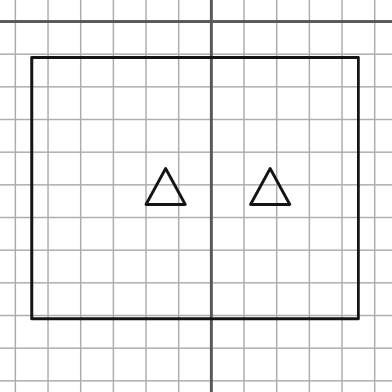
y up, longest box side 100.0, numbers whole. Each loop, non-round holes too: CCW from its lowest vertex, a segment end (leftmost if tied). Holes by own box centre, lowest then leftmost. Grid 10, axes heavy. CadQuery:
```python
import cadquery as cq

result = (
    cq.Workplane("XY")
    .moveTo(-55.0, -91.0)
    .lineTo(45.0, -91.0)
    .lineTo(45.0, -11.0)
    .lineTo(-55.0, -11.0)
    .close()
    .moveTo(-20.0, -56.0)
    .lineTo(-8.0, -56.0)
    .lineTo(-14.0, -45.0)
    .close()
    .moveTo(12.0, -56.0)
    .lineTo(24.0, -56.0)
    .lineTo(18.0, -45.0)
    .close()
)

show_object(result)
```